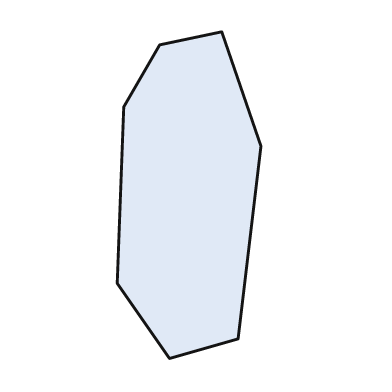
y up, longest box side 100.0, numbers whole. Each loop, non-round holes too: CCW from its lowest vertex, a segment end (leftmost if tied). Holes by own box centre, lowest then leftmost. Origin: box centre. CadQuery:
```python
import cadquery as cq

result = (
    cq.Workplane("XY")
    .moveTo(-6.0, -50.0)
    .lineTo(15.0, -44.0)
    .lineTo(22.0, 15.0)
    .lineTo(10.0, 50.0)
    .lineTo(-9.0, 46.0)
    .lineTo(-20.0, 27.0)
    .lineTo(-22.0, -27.0)
    .close()
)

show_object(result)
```